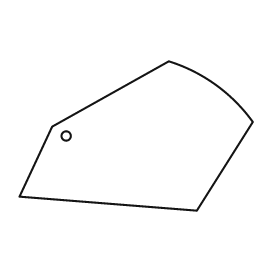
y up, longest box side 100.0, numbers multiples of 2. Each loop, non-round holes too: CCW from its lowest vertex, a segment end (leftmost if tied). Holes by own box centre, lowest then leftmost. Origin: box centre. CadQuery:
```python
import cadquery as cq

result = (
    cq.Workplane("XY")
    .moveTo(26.0, -32.0)
    .lineTo(50.0, 6.0)
    .threePointArc((34.0, 22.0), (14.0, 32.0))
    .lineTo(-36.0, 4.0)
    .lineTo(-50.0, -26.0)
    .close()
    .moveTo(-30.0, 0.0)
    .circle(2.0)
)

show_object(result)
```